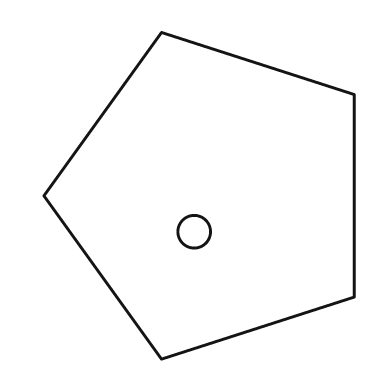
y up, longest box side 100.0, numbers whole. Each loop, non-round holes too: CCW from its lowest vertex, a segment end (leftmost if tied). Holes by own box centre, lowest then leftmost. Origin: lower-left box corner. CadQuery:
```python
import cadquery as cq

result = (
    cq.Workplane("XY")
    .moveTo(36.0, 0.0)
    .lineTo(95.0, 19.0)
    .lineTo(95.0, 81.0)
    .lineTo(36.0, 100.0)
    .lineTo(0.0, 50.0)
    .close()
    .moveTo(46.0, 39.0)
    .circle(5.0)
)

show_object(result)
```